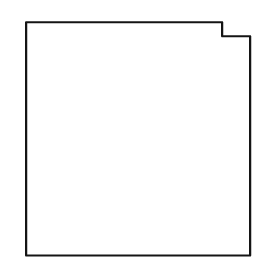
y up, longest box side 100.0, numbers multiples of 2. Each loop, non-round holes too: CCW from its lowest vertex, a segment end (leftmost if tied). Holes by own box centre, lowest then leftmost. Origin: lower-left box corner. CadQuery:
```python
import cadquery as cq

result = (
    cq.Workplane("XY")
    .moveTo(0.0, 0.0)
    .lineTo(96.0, 0.0)
    .lineTo(96.0, 94.0)
    .lineTo(84.0, 94.0)
    .lineTo(84.0, 100.0)
    .lineTo(0.0, 100.0)
    .close()
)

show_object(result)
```